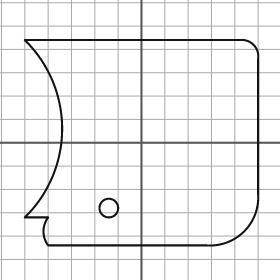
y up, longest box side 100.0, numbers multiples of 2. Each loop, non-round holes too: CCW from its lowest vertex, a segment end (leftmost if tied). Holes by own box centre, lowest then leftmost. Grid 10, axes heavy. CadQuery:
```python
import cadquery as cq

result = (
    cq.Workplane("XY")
    .moveTo(-40.0, -44.0)
    .lineTo(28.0, -44.0)
    .threePointArc((44.0, -38.0), (50.0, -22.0))
    .lineTo(50.0, 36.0)
    .threePointArc((48.0, 42.0), (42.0, 44.0))
    .lineTo(-50.0, 44.0)
    .threePointArc((-34.0, 6.0), (-50.0, -32.0))
    .lineTo(-40.0, -32.0)
    .threePointArc((-42.0, -38.0), (-40.0, -44.0))
    .close()
    .moveTo(-14.0, -28.0)
    .circle(4.0)
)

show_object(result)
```